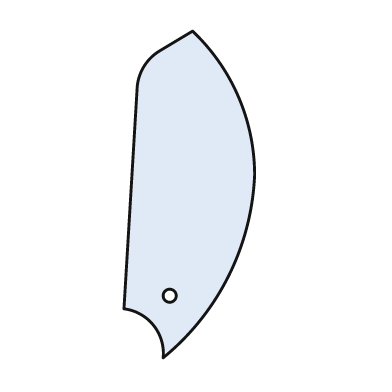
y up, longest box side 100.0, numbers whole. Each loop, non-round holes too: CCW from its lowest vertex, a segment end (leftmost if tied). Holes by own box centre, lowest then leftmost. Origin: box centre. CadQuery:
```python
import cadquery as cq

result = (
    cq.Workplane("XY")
    .moveTo(-8.0, -50.0)
    .threePointArc((12.0, -25.0), (20.0, 6.0))
    .threePointArc((15.0, 30.0), (1.0, 50.0))
    .lineTo(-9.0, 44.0)
    .threePointArc((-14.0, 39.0), (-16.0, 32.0))
    .lineTo(-20.0, -35.0)
    .threePointArc((-11.0, -40.0), (-8.0, -50.0))
    .close()
    .moveTo(-6.0, -31.0)
    .circle(2.0)
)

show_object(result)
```